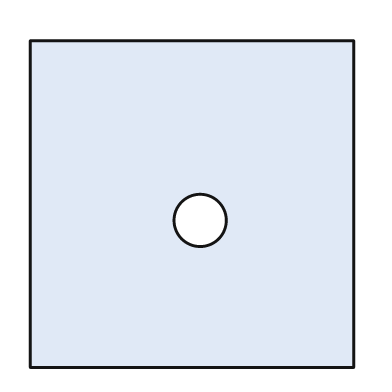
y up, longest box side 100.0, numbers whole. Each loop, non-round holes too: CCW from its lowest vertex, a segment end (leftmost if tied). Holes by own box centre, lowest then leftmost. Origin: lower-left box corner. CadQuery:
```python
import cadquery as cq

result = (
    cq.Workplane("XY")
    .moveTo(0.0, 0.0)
    .lineTo(99.0, 0.0)
    .lineTo(99.0, 100.0)
    .lineTo(0.0, 100.0)
    .close()
    .moveTo(52.0, 45.0)
    .circle(8.0)
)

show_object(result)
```